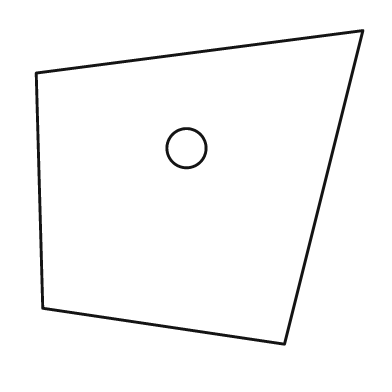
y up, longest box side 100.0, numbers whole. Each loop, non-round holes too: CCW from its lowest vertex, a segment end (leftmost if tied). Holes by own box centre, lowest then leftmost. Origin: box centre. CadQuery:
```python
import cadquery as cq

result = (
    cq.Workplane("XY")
    .moveTo(26.0, -48.0)
    .lineTo(50.0, 48.0)
    .lineTo(-50.0, 35.0)
    .lineTo(-48.0, -37.0)
    .close()
    .moveTo(-4.0, 12.0)
    .circle(6.0)
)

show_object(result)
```